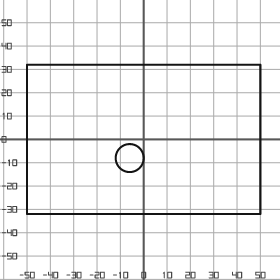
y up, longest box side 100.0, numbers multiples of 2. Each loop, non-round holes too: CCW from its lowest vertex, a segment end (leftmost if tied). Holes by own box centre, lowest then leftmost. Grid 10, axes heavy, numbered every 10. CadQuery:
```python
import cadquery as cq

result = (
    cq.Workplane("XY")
    .moveTo(-50.0, -32.0)
    .lineTo(50.0, -32.0)
    .lineTo(50.0, 32.0)
    .lineTo(-50.0, 32.0)
    .close()
    .moveTo(-6.0, -8.0)
    .circle(6.0)
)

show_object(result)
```